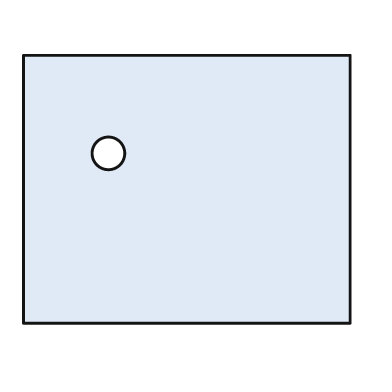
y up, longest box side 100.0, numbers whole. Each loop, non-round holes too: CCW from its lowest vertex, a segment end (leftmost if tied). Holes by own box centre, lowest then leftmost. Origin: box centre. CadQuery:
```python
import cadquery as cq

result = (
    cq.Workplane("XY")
    .moveTo(-50.0, -41.0)
    .lineTo(50.0, -41.0)
    .lineTo(50.0, 41.0)
    .lineTo(-50.0, 41.0)
    .close()
    .moveTo(-24.0, 11.0)
    .circle(5.0)
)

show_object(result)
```